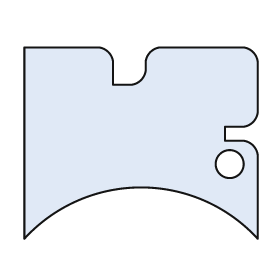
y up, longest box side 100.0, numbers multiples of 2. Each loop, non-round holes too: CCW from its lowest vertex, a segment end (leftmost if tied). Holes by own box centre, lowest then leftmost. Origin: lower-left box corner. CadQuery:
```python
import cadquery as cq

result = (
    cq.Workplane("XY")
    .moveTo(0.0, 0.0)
    .threePointArc((50.0, 22.0), (100.0, 0.0))
    .lineTo(100.0, 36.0)
    .threePointArc((98.0, 40.0), (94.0, 42.0))
    .lineTo(86.0, 42.0)
    .lineTo(86.0, 48.0)
    .lineTo(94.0, 48.0)
    .threePointArc((98.0, 50.0), (100.0, 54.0))
    .lineTo(100.0, 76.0)
    .threePointArc((98.0, 80.0), (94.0, 82.0))
    .lineTo(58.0, 82.0)
    .threePointArc((54.0, 80.0), (52.0, 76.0))
    .lineTo(52.0, 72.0)
    .threePointArc((50.0, 68.0), (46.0, 66.0))
    .lineTo(38.0, 66.0)
    .lineTo(38.0, 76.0)
    .threePointArc((36.0, 80.0), (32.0, 82.0))
    .lineTo(0.0, 82.0)
    .close()
    .moveTo(88.0, 32.0)
    .circle(6.0)
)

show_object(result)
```